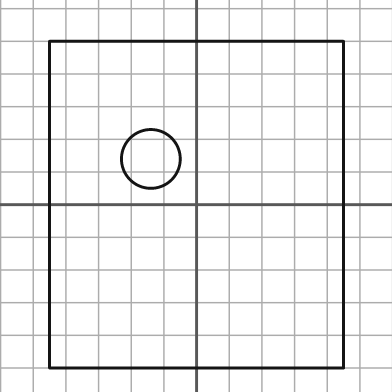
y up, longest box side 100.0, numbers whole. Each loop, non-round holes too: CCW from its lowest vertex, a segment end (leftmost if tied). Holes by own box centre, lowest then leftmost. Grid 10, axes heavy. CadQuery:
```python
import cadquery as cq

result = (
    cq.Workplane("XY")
    .moveTo(-45.0, -50.0)
    .lineTo(45.0, -50.0)
    .lineTo(45.0, 50.0)
    .lineTo(-45.0, 50.0)
    .close()
    .moveTo(-14.0, 14.0)
    .circle(9.0)
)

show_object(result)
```